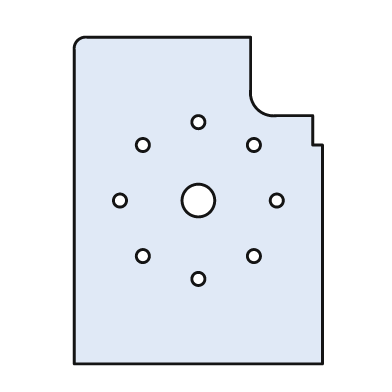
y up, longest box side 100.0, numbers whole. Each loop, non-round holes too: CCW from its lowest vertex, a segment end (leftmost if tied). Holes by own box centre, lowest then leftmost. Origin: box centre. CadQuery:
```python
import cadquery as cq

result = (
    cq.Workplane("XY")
    .moveTo(-38.0, -50.0)
    .lineTo(38.0, -50.0)
    .lineTo(38.0, 17.0)
    .lineTo(35.0, 17.0)
    .lineTo(35.0, 26.0)
    .lineTo(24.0, 26.0)
    .threePointArc((18.0, 28.0), (16.0, 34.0))
    .lineTo(16.0, 50.0)
    .lineTo(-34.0, 50.0)
    .threePointArc((-37.0, 49.0), (-38.0, 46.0))
    .close()
    .moveTo(0.0, -24.0)
    .circle(2.0)
    .moveTo(-17.0, -17.0)
    .circle(2.0)
    .moveTo(17.0, -17.0)
    .circle(2.0)
    .moveTo(-24.0, 0.0)
    .circle(2.0)
    .moveTo(0.0, 0.0)
    .circle(5.0)
    .moveTo(24.0, 0.0)
    .circle(2.0)
    .moveTo(-17.0, 17.0)
    .circle(2.0)
    .moveTo(17.0, 17.0)
    .circle(2.0)
    .moveTo(0.0, 24.0)
    .circle(2.0)
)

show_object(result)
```